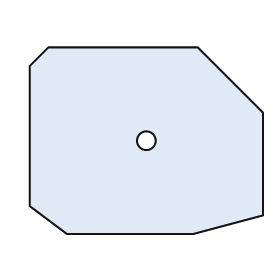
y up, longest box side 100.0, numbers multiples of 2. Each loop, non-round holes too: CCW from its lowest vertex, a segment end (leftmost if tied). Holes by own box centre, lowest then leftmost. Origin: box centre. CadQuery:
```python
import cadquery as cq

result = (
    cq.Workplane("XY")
    .moveTo(-34.0, -40.0)
    .lineTo(20.0, -40.0)
    .lineTo(50.0, -32.0)
    .lineTo(50.0, 12.0)
    .lineTo(22.0, 40.0)
    .lineTo(-42.0, 40.0)
    .lineTo(-50.0, 32.0)
    .lineTo(-50.0, -28.0)
    .close()
    .moveTo(0.0, 0.0)
    .circle(4.0)
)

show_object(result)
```